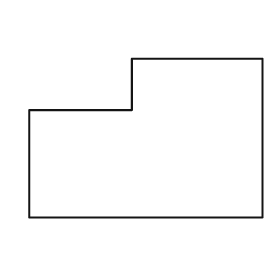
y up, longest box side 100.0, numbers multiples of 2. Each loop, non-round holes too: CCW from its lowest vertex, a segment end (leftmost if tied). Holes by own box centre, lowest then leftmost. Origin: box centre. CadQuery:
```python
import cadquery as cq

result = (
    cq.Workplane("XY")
    .moveTo(-50.0, -34.0)
    .lineTo(50.0, -34.0)
    .lineTo(50.0, 34.0)
    .lineTo(-6.0, 34.0)
    .lineTo(-6.0, 12.0)
    .lineTo(-50.0, 12.0)
    .close()
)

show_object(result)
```